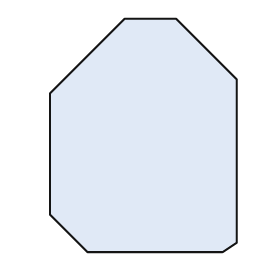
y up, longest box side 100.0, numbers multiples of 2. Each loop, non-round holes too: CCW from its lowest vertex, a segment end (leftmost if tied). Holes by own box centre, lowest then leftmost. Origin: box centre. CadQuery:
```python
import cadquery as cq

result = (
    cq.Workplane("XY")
    .moveTo(-24.0, -50.0)
    .lineTo(34.0, -50.0)
    .lineTo(40.0, -46.0)
    .lineTo(40.0, 24.0)
    .lineTo(14.0, 50.0)
    .lineTo(-8.0, 50.0)
    .lineTo(-40.0, 18.0)
    .lineTo(-40.0, -34.0)
    .close()
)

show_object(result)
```